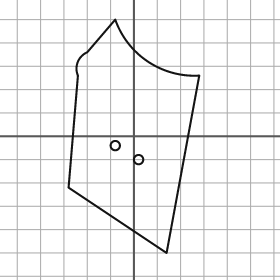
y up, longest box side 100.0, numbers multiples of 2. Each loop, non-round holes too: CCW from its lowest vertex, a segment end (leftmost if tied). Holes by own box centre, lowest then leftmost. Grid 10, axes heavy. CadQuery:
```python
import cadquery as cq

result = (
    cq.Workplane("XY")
    .moveTo(14.0, -50.0)
    .lineTo(28.0, 26.0)
    .threePointArc((6.0, 32.0), (-8.0, 50.0))
    .lineTo(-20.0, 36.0)
    .threePointArc((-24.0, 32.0), (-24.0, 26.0))
    .lineTo(-28.0, -22.0)
    .close()
    .moveTo(2.0, -10.0)
    .circle(2.0)
    .moveTo(-8.0, -4.0)
    .circle(2.0)
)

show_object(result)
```